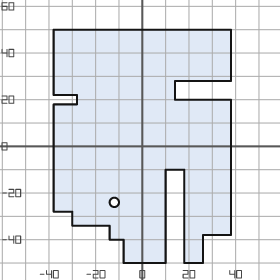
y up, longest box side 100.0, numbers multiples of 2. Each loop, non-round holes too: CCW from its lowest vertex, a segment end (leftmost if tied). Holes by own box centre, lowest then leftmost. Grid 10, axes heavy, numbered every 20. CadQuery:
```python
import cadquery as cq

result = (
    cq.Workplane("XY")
    .moveTo(-8.0, -50.0)
    .lineTo(10.0, -50.0)
    .lineTo(10.0, -10.0)
    .lineTo(18.0, -10.0)
    .lineTo(18.0, -50.0)
    .lineTo(26.0, -50.0)
    .lineTo(26.0, -38.0)
    .lineTo(38.0, -38.0)
    .lineTo(38.0, 20.0)
    .lineTo(14.0, 20.0)
    .lineTo(14.0, 28.0)
    .lineTo(38.0, 28.0)
    .lineTo(38.0, 50.0)
    .lineTo(-38.0, 50.0)
    .lineTo(-38.0, 22.0)
    .lineTo(-28.0, 22.0)
    .lineTo(-28.0, 18.0)
    .lineTo(-38.0, 18.0)
    .lineTo(-38.0, -28.0)
    .lineTo(-30.0, -28.0)
    .lineTo(-30.0, -34.0)
    .lineTo(-14.0, -34.0)
    .lineTo(-14.0, -40.0)
    .lineTo(-8.0, -40.0)
    .close()
    .moveTo(-12.0, -24.0)
    .circle(2.0)
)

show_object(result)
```